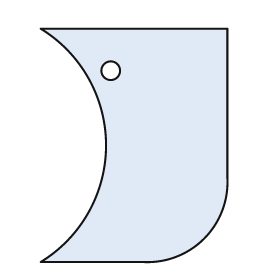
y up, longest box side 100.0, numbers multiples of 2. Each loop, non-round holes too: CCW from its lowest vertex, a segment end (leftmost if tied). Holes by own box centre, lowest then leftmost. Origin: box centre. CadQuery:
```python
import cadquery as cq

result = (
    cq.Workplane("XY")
    .moveTo(-40.0, -50.0)
    .lineTo(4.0, -50.0)
    .threePointArc((30.0, -40.0), (40.0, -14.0))
    .lineTo(40.0, 50.0)
    .lineTo(-40.0, 50.0)
    .threePointArc((-12.0, 0.0), (-40.0, -50.0))
    .close()
    .moveTo(-10.0, 32.0)
    .circle(4.0)
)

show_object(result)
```